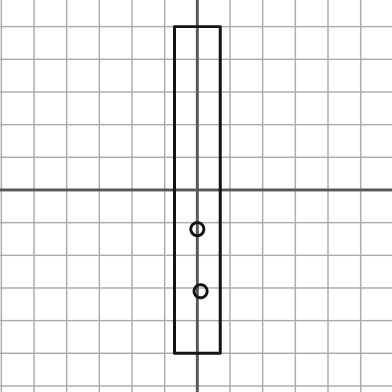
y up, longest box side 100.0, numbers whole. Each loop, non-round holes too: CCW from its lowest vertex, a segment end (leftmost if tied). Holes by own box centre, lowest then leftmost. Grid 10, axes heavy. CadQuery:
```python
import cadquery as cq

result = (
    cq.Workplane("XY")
    .moveTo(-7.0, -50.0)
    .lineTo(7.0, -50.0)
    .lineTo(7.0, 50.0)
    .lineTo(-7.0, 50.0)
    .close()
    .moveTo(1.0, -31.0)
    .circle(2.0)
    .moveTo(0.0, -12.0)
    .circle(2.0)
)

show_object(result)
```